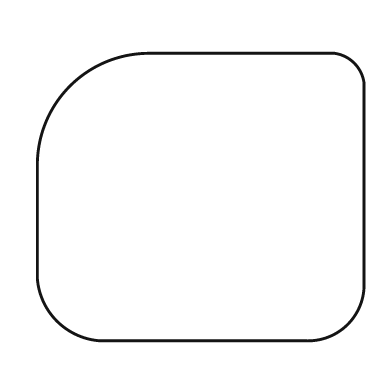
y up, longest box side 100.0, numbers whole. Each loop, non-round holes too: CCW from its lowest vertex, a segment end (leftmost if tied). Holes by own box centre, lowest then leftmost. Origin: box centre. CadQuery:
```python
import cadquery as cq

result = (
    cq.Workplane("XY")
    .moveTo(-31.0, -44.0)
    .lineTo(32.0, -44.0)
    .threePointArc((45.0, -39.0), (50.0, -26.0))
    .lineTo(50.0, 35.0)
    .threePointArc((47.0, 41.0), (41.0, 44.0))
    .lineTo(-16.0, 44.0)
    .threePointArc((-40.0, 34.0), (-50.0, 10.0))
    .lineTo(-50.0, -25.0)
    .threePointArc((-44.0, -38.0), (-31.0, -44.0))
    .close()
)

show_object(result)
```